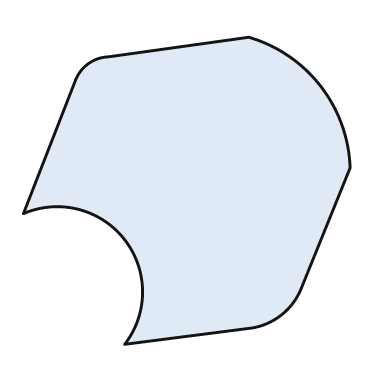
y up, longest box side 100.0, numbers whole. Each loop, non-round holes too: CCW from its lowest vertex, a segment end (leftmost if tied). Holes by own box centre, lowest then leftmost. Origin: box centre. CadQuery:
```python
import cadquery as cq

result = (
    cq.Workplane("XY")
    .moveTo(-19.0, -47.0)
    .lineTo(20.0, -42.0)
    .threePointArc((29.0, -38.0), (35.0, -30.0))
    .lineTo(50.0, 7.0)
    .threePointArc((41.0, 32.0), (19.0, 47.0))
    .lineTo(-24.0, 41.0)
    .threePointArc((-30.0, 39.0), (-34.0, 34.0))
    .lineTo(-50.0, -7.0)
    .threePointArc((-19.0, -15.0), (-19.0, -47.0))
    .close()
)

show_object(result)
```